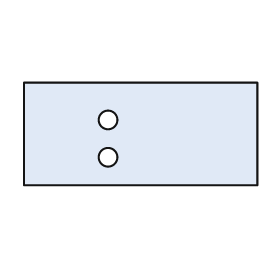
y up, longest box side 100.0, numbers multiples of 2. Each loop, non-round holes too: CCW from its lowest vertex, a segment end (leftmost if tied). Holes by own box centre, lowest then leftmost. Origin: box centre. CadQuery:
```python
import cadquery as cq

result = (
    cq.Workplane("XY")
    .moveTo(-50.0, -22.0)
    .lineTo(50.0, -22.0)
    .lineTo(50.0, 22.0)
    .lineTo(-50.0, 22.0)
    .close()
    .moveTo(-14.0, -10.0)
    .circle(4.0)
    .moveTo(-14.0, 6.0)
    .circle(4.0)
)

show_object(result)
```